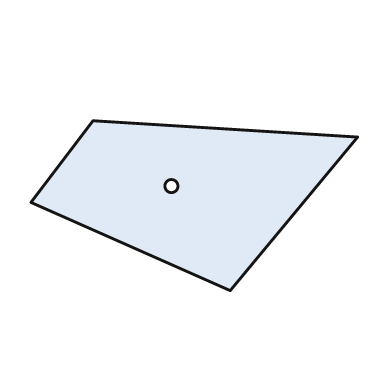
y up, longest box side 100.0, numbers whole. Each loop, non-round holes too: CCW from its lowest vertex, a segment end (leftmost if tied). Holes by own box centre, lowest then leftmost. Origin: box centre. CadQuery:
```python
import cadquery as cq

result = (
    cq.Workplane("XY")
    .moveTo(11.0, -26.0)
    .lineTo(50.0, 21.0)
    .lineTo(-31.0, 26.0)
    .lineTo(-50.0, 1.0)
    .close()
    .moveTo(-7.0, 6.0)
    .circle(2.0)
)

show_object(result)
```